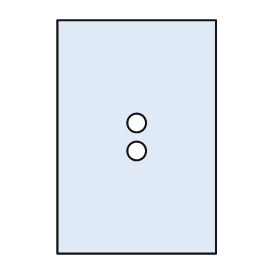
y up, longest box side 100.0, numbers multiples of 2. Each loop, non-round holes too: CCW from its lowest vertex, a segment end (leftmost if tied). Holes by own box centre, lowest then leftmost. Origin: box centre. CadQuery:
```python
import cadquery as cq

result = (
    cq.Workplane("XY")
    .moveTo(-34.0, -50.0)
    .lineTo(34.0, -50.0)
    .lineTo(34.0, 50.0)
    .lineTo(-34.0, 50.0)
    .close()
    .moveTo(0.0, -6.0)
    .circle(4.0)
    .moveTo(0.0, 6.0)
    .circle(4.0)
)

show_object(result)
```